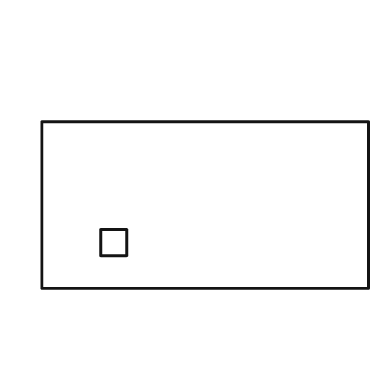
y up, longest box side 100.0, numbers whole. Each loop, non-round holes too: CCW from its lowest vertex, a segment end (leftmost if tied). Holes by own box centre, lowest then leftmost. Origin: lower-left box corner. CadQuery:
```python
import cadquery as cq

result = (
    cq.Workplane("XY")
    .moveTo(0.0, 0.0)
    .lineTo(100.0, 0.0)
    .lineTo(100.0, 51.0)
    .lineTo(0.0, 51.0)
    .close()
    .moveTo(18.0, 10.0)
    .lineTo(26.0, 10.0)
    .lineTo(26.0, 18.0)
    .lineTo(18.0, 18.0)
    .close()
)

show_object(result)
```